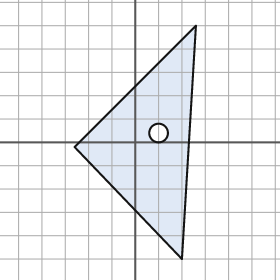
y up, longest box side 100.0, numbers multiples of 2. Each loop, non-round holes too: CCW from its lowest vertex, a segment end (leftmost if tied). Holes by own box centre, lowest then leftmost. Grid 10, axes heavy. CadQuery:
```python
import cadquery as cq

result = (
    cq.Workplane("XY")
    .moveTo(20.0, -50.0)
    .lineTo(26.0, 50.0)
    .lineTo(-26.0, -2.0)
    .close()
    .moveTo(10.0, 4.0)
    .circle(4.0)
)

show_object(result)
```